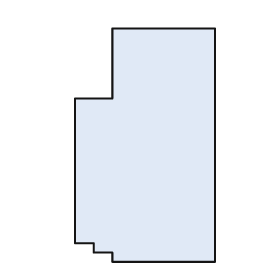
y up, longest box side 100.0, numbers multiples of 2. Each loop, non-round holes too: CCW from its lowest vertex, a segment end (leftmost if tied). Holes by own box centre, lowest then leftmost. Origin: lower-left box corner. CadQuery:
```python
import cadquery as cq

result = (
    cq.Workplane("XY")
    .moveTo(16.0, 0.0)
    .lineTo(60.0, 0.0)
    .lineTo(60.0, 100.0)
    .lineTo(16.0, 100.0)
    .lineTo(16.0, 70.0)
    .lineTo(0.0, 70.0)
    .lineTo(0.0, 8.0)
    .lineTo(8.0, 8.0)
    .lineTo(8.0, 4.0)
    .lineTo(16.0, 4.0)
    .close()
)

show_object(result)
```